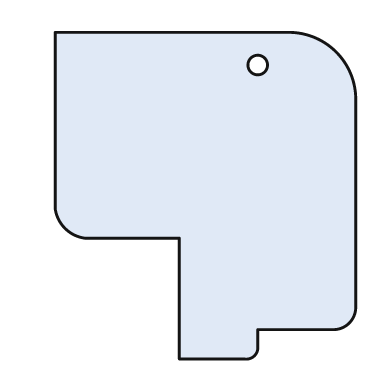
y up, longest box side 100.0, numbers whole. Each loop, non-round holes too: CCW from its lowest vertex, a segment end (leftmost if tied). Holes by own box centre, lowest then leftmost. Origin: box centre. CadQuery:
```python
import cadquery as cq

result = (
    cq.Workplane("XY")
    .moveTo(-8.0, -50.0)
    .lineTo(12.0, -50.0)
    .threePointArc((15.0, -49.0), (16.0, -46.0))
    .lineTo(16.0, -41.0)
    .lineTo(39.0, -41.0)
    .threePointArc((44.0, -39.0), (46.0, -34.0))
    .lineTo(46.0, 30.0)
    .threePointArc((40.0, 44.0), (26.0, 50.0))
    .lineTo(-46.0, 50.0)
    .lineTo(-46.0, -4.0)
    .threePointArc((-43.0, -10.0), (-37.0, -13.0))
    .lineTo(-8.0, -13.0)
    .close()
    .moveTo(16.0, 40.0)
    .circle(3.0)
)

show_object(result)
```